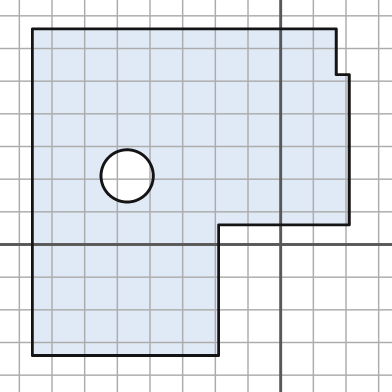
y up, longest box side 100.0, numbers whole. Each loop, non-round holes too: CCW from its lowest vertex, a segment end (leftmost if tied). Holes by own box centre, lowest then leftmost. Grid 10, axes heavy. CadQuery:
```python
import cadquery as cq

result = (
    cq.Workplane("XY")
    .moveTo(-76.0, -34.0)
    .lineTo(-19.0, -34.0)
    .lineTo(-19.0, 6.0)
    .lineTo(21.0, 6.0)
    .lineTo(21.0, 52.0)
    .lineTo(17.0, 52.0)
    .lineTo(17.0, 66.0)
    .lineTo(-76.0, 66.0)
    .close()
    .moveTo(-47.0, 21.0)
    .circle(8.0)
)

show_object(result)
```